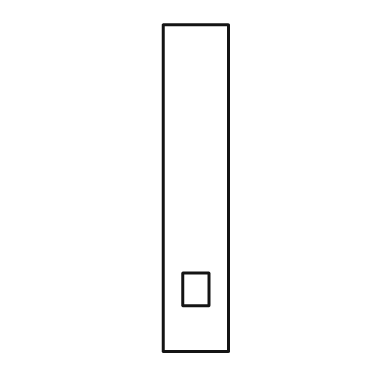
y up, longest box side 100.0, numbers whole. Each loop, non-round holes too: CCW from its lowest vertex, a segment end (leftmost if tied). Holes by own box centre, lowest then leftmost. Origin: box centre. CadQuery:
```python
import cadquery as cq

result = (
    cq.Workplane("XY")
    .moveTo(-10.0, -50.0)
    .lineTo(10.0, -50.0)
    .lineTo(10.0, 50.0)
    .lineTo(-10.0, 50.0)
    .close()
    .moveTo(-4.0, -36.0)
    .lineTo(4.0, -36.0)
    .lineTo(4.0, -26.0)
    .lineTo(-4.0, -26.0)
    .close()
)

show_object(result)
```